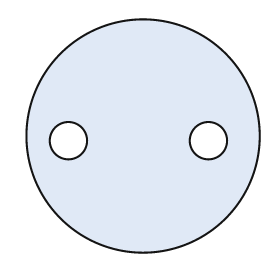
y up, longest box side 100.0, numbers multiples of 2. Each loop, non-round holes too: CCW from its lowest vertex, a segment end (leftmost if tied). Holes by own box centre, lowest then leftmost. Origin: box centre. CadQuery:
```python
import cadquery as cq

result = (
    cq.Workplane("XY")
    .moveTo(0.0, 0.0)
    .circle(50.0)
    .moveTo(-32.0, -2.0)
    .circle(8.0)
    .moveTo(28.0, -2.0)
    .circle(8.0)
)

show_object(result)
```